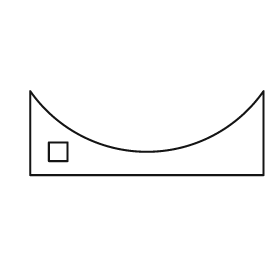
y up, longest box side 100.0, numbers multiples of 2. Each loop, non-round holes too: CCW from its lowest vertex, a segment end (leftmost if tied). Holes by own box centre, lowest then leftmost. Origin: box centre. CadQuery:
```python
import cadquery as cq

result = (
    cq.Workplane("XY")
    .moveTo(-50.0, -18.0)
    .lineTo(50.0, -18.0)
    .lineTo(50.0, 18.0)
    .threePointArc((0.0, -8.0), (-50.0, 18.0))
    .close()
    .moveTo(-42.0, -12.0)
    .lineTo(-34.0, -12.0)
    .lineTo(-34.0, -4.0)
    .lineTo(-42.0, -4.0)
    .close()
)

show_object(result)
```